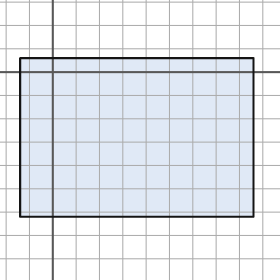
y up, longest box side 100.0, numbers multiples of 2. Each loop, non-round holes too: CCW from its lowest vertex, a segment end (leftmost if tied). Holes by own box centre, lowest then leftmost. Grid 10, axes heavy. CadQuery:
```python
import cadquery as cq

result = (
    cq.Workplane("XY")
    .moveTo(-14.0, -62.0)
    .lineTo(86.0, -62.0)
    .lineTo(86.0, 6.0)
    .lineTo(-14.0, 6.0)
    .close()
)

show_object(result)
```